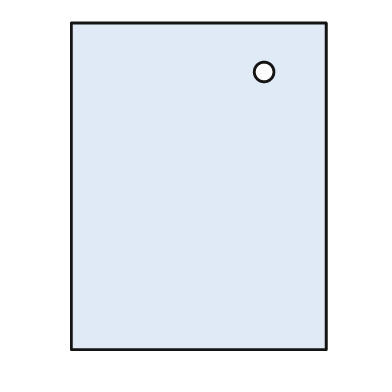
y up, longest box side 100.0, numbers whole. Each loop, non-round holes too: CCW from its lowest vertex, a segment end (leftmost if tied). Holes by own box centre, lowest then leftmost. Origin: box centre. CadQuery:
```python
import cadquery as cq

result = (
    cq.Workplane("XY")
    .moveTo(-39.0, -50.0)
    .lineTo(39.0, -50.0)
    .lineTo(39.0, 50.0)
    .lineTo(-39.0, 50.0)
    .close()
    .moveTo(20.0, 35.0)
    .circle(3.0)
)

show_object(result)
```